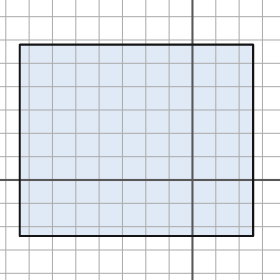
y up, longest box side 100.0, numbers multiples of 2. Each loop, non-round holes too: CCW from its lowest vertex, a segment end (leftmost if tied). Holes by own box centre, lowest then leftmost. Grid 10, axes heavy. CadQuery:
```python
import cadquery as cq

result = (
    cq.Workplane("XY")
    .moveTo(-74.0, -24.0)
    .lineTo(26.0, -24.0)
    .lineTo(26.0, 58.0)
    .lineTo(-74.0, 58.0)
    .close()
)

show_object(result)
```